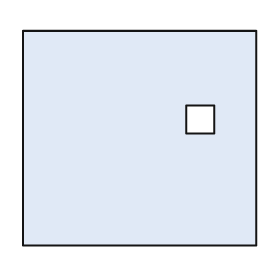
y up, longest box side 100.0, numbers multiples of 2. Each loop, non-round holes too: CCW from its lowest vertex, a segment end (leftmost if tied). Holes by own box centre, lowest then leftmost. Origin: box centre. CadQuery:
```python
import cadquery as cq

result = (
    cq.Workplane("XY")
    .moveTo(-50.0, -46.0)
    .lineTo(50.0, -46.0)
    .lineTo(50.0, 46.0)
    .lineTo(-50.0, 46.0)
    .close()
    .moveTo(20.0, 2.0)
    .lineTo(32.0, 2.0)
    .lineTo(32.0, 14.0)
    .lineTo(20.0, 14.0)
    .close()
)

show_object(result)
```